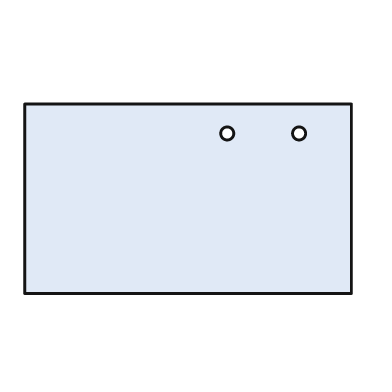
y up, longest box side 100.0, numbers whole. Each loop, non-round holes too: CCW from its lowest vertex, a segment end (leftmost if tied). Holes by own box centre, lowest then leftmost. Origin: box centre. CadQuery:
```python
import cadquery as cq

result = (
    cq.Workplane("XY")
    .moveTo(-50.0, -29.0)
    .lineTo(50.0, -29.0)
    .lineTo(50.0, 29.0)
    .lineTo(-50.0, 29.0)
    .close()
    .moveTo(12.0, 20.0)
    .circle(2.0)
    .moveTo(34.0, 20.0)
    .circle(2.0)
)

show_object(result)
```